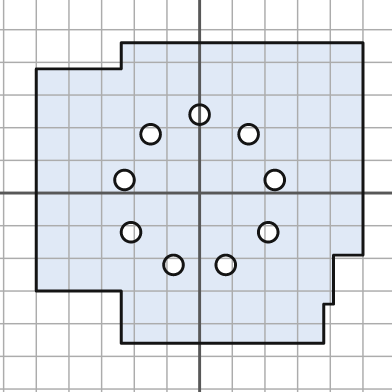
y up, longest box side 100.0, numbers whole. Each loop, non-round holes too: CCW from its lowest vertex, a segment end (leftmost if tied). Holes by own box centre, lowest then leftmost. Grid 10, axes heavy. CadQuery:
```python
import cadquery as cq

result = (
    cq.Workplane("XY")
    .moveTo(-24.0, -46.0)
    .lineTo(38.0, -46.0)
    .lineTo(38.0, -34.0)
    .lineTo(41.0, -34.0)
    .lineTo(41.0, -19.0)
    .lineTo(50.0, -19.0)
    .lineTo(50.0, 46.0)
    .lineTo(-24.0, 46.0)
    .lineTo(-24.0, 38.0)
    .lineTo(-50.0, 38.0)
    .lineTo(-50.0, -30.0)
    .lineTo(-24.0, -30.0)
    .close()
    .moveTo(-8.0, -22.0)
    .circle(3.0)
    .moveTo(8.0, -22.0)
    .circle(3.0)
    .moveTo(-21.0, -12.0)
    .circle(3.0)
    .moveTo(21.0, -12.0)
    .circle(3.0)
    .moveTo(-23.0, 4.0)
    .circle(3.0)
    .moveTo(23.0, 4.0)
    .circle(3.0)
    .moveTo(-15.0, 18.0)
    .circle(3.0)
    .moveTo(15.0, 18.0)
    .circle(3.0)
    .moveTo(0.0, 24.0)
    .circle(3.0)
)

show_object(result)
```